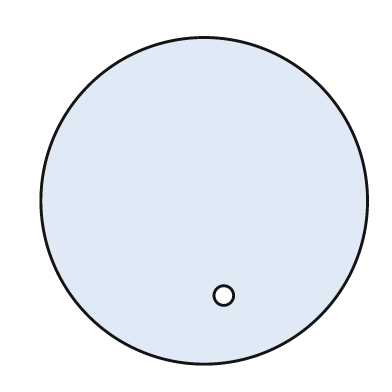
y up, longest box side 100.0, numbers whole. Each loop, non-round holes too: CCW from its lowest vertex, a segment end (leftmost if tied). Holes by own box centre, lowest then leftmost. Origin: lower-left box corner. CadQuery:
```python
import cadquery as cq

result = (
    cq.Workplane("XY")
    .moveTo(50.0, 50.0)
    .circle(50.0)
    .moveTo(56.0, 21.0)
    .circle(3.0)
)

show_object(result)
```